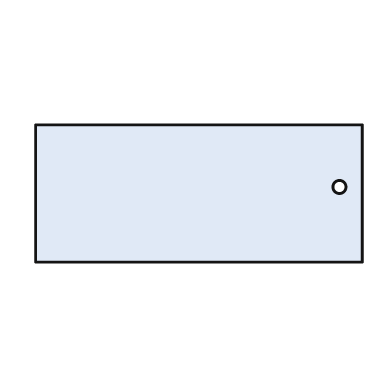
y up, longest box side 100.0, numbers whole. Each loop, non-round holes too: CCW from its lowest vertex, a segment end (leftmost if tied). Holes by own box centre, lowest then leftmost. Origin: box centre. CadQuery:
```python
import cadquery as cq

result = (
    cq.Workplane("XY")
    .moveTo(-50.0, -21.0)
    .lineTo(50.0, -21.0)
    .lineTo(50.0, 21.0)
    .lineTo(-50.0, 21.0)
    .close()
    .moveTo(43.0, 2.0)
    .circle(2.0)
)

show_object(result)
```